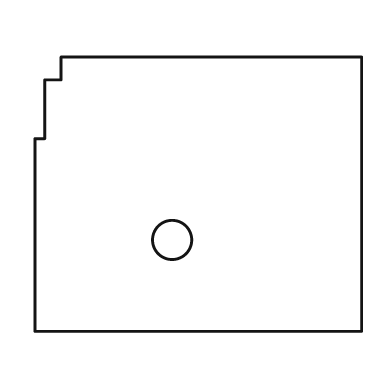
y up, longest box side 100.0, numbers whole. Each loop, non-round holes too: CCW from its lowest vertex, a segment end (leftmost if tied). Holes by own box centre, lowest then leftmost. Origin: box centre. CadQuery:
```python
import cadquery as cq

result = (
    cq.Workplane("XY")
    .moveTo(-50.0, -42.0)
    .lineTo(50.0, -42.0)
    .lineTo(50.0, 42.0)
    .lineTo(-42.0, 42.0)
    .lineTo(-42.0, 35.0)
    .lineTo(-47.0, 35.0)
    .lineTo(-47.0, 17.0)
    .lineTo(-50.0, 17.0)
    .close()
    .moveTo(-8.0, -14.0)
    .circle(6.0)
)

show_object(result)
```